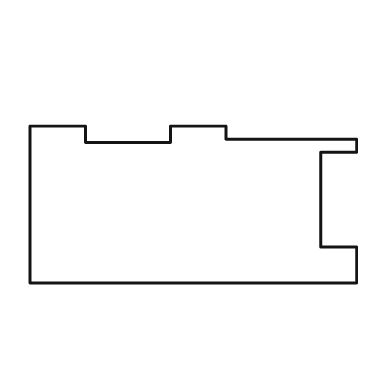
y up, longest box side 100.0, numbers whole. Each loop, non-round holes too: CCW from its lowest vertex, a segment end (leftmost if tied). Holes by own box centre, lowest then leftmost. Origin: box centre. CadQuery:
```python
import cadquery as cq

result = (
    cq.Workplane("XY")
    .moveTo(-50.0, -24.0)
    .lineTo(50.0, -24.0)
    .lineTo(50.0, -13.0)
    .lineTo(39.0, -13.0)
    .lineTo(39.0, 16.0)
    .lineTo(50.0, 16.0)
    .lineTo(50.0, 20.0)
    .lineTo(10.0, 20.0)
    .lineTo(10.0, 24.0)
    .lineTo(-7.0, 24.0)
    .lineTo(-7.0, 19.0)
    .lineTo(-33.0, 19.0)
    .lineTo(-33.0, 24.0)
    .lineTo(-50.0, 24.0)
    .close()
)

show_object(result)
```